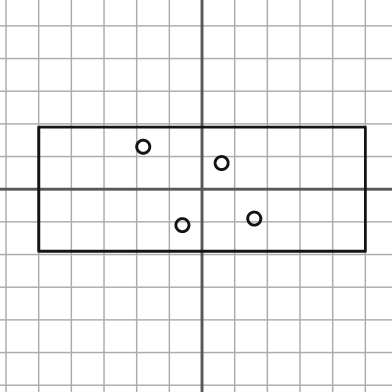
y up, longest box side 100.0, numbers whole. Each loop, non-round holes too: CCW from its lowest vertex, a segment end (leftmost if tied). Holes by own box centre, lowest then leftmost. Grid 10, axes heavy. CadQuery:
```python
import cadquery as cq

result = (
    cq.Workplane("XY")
    .moveTo(-50.0, -19.0)
    .lineTo(50.0, -19.0)
    .lineTo(50.0, 19.0)
    .lineTo(-50.0, 19.0)
    .close()
    .moveTo(-6.0, -11.0)
    .circle(2.0)
    .moveTo(16.0, -9.0)
    .circle(2.0)
    .moveTo(6.0, 8.0)
    .circle(2.0)
    .moveTo(-18.0, 13.0)
    .circle(2.0)
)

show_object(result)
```